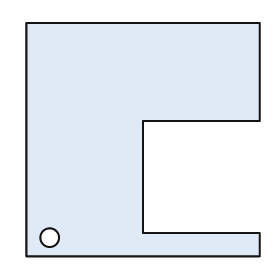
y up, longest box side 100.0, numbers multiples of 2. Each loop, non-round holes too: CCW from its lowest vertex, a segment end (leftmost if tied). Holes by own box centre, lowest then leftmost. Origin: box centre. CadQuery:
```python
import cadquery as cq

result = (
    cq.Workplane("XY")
    .moveTo(-50.0, -50.0)
    .lineTo(50.0, -50.0)
    .lineTo(50.0, -40.0)
    .lineTo(0.0, -40.0)
    .lineTo(0.0, 8.0)
    .lineTo(50.0, 8.0)
    .lineTo(50.0, 50.0)
    .lineTo(-50.0, 50.0)
    .close()
    .moveTo(-40.0, -42.0)
    .circle(4.0)
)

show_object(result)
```